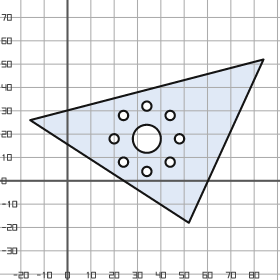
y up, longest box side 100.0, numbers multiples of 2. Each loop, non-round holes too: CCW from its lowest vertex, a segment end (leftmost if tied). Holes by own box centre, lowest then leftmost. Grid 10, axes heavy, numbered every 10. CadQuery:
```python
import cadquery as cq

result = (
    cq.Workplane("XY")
    .moveTo(52.0, -18.0)
    .lineTo(84.0, 52.0)
    .lineTo(-16.0, 26.0)
    .close()
    .moveTo(34.0, 4.0)
    .circle(2.0)
    .moveTo(24.0, 8.0)
    .circle(2.0)
    .moveTo(44.0, 8.0)
    .circle(2.0)
    .moveTo(20.0, 18.0)
    .circle(2.0)
    .moveTo(34.0, 18.0)
    .circle(6.0)
    .moveTo(48.0, 18.0)
    .circle(2.0)
    .moveTo(24.0, 28.0)
    .circle(2.0)
    .moveTo(44.0, 28.0)
    .circle(2.0)
    .moveTo(34.0, 32.0)
    .circle(2.0)
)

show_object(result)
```